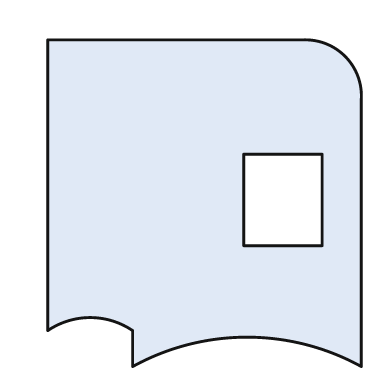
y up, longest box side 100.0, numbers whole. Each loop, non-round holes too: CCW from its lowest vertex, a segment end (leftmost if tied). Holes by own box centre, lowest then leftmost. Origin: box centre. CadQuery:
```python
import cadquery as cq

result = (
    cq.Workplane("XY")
    .moveTo(-22.0, -50.0)
    .threePointArc((13.0, -41.0), (48.0, -50.0))
    .lineTo(48.0, 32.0)
    .threePointArc((43.0, 45.0), (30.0, 50.0))
    .lineTo(-48.0, 50.0)
    .lineTo(-48.0, -39.0)
    .threePointArc((-35.0, -35.0), (-22.0, -39.0))
    .close()
    .moveTo(12.0, -13.0)
    .lineTo(36.0, -13.0)
    .lineTo(36.0, 15.0)
    .lineTo(12.0, 15.0)
    .close()
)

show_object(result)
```